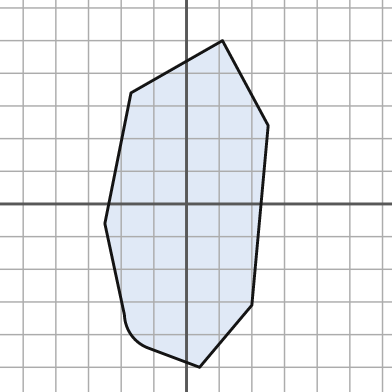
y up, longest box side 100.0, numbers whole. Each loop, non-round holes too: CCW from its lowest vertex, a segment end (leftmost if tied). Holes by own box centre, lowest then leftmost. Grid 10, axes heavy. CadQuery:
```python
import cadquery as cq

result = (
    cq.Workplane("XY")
    .moveTo(4.0, -50.0)
    .lineTo(20.0, -31.0)
    .lineTo(25.0, 24.0)
    .lineTo(11.0, 50.0)
    .lineTo(-17.0, 34.0)
    .lineTo(-25.0, -6.0)
    .lineTo(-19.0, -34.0)
    .threePointArc((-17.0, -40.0), (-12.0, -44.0))
    .close()
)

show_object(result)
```